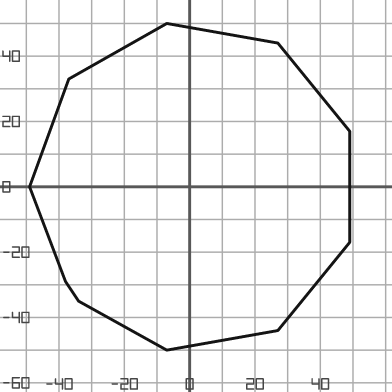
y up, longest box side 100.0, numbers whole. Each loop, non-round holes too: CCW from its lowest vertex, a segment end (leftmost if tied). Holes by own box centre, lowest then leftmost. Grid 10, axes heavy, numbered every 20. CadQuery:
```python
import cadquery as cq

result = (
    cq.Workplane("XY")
    .moveTo(-7.0, -50.0)
    .lineTo(27.0, -44.0)
    .lineTo(49.0, -17.0)
    .lineTo(49.0, 17.0)
    .lineTo(27.0, 44.0)
    .lineTo(-7.0, 50.0)
    .lineTo(-37.0, 33.0)
    .lineTo(-49.0, 0.0)
    .lineTo(-38.0, -29.0)
    .lineTo(-34.0, -35.0)
    .close()
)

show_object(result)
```